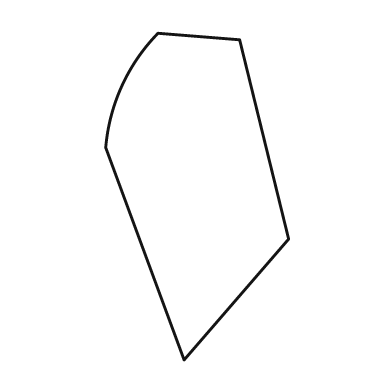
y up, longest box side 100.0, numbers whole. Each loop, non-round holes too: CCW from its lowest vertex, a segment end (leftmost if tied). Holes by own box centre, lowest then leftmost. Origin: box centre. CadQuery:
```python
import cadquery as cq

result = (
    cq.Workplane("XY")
    .moveTo(-4.0, -50.0)
    .lineTo(28.0, -13.0)
    .lineTo(13.0, 48.0)
    .lineTo(-12.0, 50.0)
    .threePointArc((-23.0, 34.0), (-28.0, 15.0))
    .close()
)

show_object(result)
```